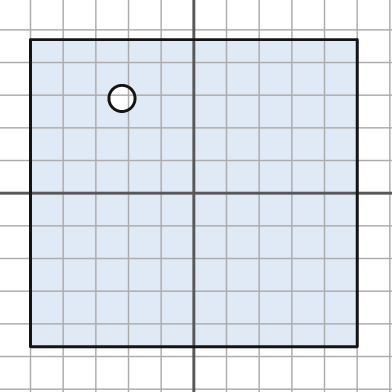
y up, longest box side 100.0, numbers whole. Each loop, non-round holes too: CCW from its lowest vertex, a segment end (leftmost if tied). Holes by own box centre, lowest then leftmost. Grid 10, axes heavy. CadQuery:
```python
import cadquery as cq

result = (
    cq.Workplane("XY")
    .moveTo(-50.0, -47.0)
    .lineTo(50.0, -47.0)
    .lineTo(50.0, 47.0)
    .lineTo(-50.0, 47.0)
    .close()
    .moveTo(-22.0, 29.0)
    .circle(4.0)
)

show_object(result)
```